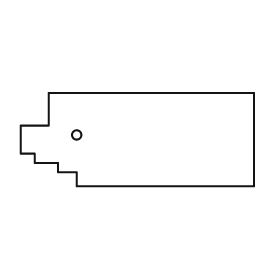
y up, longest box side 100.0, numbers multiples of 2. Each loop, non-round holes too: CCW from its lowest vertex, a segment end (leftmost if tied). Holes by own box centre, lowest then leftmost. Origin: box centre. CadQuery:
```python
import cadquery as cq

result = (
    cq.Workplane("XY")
    .moveTo(-26.0, -20.0)
    .lineTo(50.0, -20.0)
    .lineTo(50.0, 20.0)
    .lineTo(-38.0, 20.0)
    .lineTo(-38.0, 6.0)
    .lineTo(-50.0, 6.0)
    .lineTo(-50.0, -6.0)
    .lineTo(-44.0, -6.0)
    .lineTo(-44.0, -10.0)
    .lineTo(-34.0, -10.0)
    .lineTo(-34.0, -14.0)
    .lineTo(-26.0, -14.0)
    .close()
    .moveTo(-26.0, 2.0)
    .circle(2.0)
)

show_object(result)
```